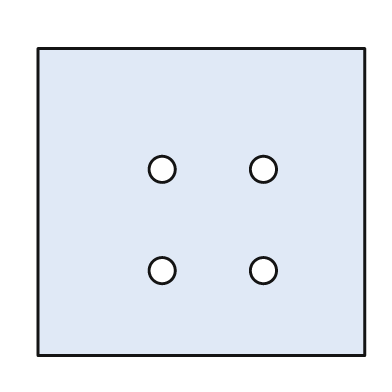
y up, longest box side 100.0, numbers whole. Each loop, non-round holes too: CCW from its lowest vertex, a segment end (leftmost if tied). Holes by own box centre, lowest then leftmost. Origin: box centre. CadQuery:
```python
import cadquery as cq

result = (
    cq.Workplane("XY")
    .moveTo(-50.0, -47.0)
    .lineTo(50.0, -47.0)
    .lineTo(50.0, 47.0)
    .lineTo(-50.0, 47.0)
    .close()
    .moveTo(-12.0, -21.0)
    .circle(4.0)
    .moveTo(19.0, -21.0)
    .circle(4.0)
    .moveTo(-12.0, 10.0)
    .circle(4.0)
    .moveTo(19.0, 10.0)
    .circle(4.0)
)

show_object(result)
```